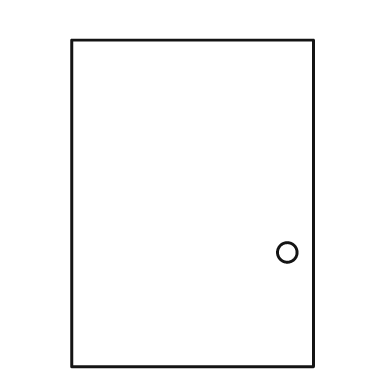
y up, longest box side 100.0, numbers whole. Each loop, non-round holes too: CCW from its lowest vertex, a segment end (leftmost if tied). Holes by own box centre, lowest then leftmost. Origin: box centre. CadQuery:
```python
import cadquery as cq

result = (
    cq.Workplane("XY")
    .moveTo(-37.0, -50.0)
    .lineTo(37.0, -50.0)
    .lineTo(37.0, 50.0)
    .lineTo(-37.0, 50.0)
    .close()
    .moveTo(29.0, -15.0)
    .circle(3.0)
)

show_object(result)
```